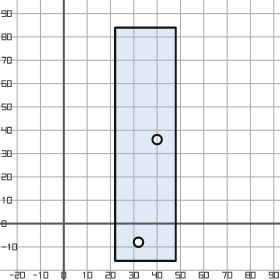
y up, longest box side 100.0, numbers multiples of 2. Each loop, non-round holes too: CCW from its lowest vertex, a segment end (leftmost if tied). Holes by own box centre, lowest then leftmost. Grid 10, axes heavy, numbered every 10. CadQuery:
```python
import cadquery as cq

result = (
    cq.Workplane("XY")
    .moveTo(22.0, -16.0)
    .lineTo(48.0, -16.0)
    .lineTo(48.0, 84.0)
    .lineTo(22.0, 84.0)
    .close()
    .moveTo(32.0, -8.0)
    .circle(2.0)
    .moveTo(40.0, 36.0)
    .circle(2.0)
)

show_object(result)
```